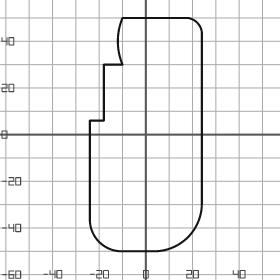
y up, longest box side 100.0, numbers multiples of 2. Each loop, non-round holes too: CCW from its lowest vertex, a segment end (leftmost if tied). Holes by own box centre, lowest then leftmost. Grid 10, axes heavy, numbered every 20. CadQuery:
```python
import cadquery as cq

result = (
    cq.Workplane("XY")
    .moveTo(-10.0, -50.0)
    .lineTo(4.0, -50.0)
    .threePointArc((18.0, -44.0), (24.0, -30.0))
    .lineTo(24.0, 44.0)
    .threePointArc((22.0, 48.0), (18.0, 50.0))
    .lineTo(-10.0, 50.0)
    .threePointArc((-12.0, 40.0), (-10.0, 30.0))
    .lineTo(-18.0, 30.0)
    .lineTo(-18.0, 6.0)
    .lineTo(-24.0, 6.0)
    .lineTo(-24.0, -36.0)
    .threePointArc((-20.0, -46.0), (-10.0, -50.0))
    .close()
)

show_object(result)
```